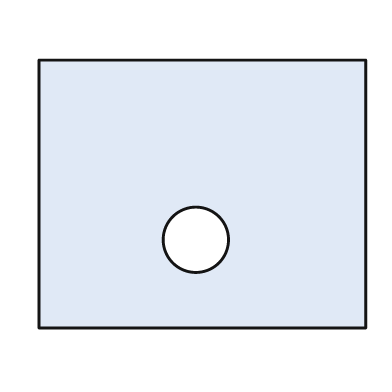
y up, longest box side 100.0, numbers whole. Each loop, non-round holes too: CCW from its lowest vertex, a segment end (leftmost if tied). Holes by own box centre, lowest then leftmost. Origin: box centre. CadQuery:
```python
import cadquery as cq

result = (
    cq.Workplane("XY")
    .moveTo(-50.0, -41.0)
    .lineTo(50.0, -41.0)
    .lineTo(50.0, 41.0)
    .lineTo(-50.0, 41.0)
    .close()
    .moveTo(-2.0, -14.0)
    .circle(10.0)
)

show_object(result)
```